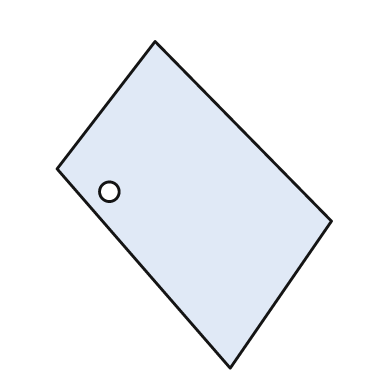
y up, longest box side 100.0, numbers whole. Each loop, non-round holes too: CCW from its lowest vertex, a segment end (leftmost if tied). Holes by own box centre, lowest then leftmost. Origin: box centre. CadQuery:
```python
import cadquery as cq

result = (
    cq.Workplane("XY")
    .moveTo(11.0, -50.0)
    .lineTo(42.0, -5.0)
    .lineTo(-12.0, 50.0)
    .lineTo(-42.0, 11.0)
    .close()
    .moveTo(-26.0, 4.0)
    .circle(3.0)
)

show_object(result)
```